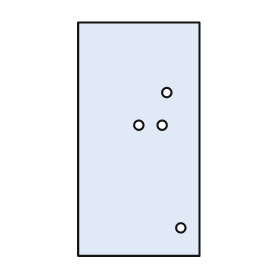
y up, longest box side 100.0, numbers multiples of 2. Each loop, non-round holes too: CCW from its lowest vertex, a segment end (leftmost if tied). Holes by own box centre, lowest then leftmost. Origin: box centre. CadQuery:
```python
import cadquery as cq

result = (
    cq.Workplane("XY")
    .moveTo(-26.0, -50.0)
    .lineTo(26.0, -50.0)
    .lineTo(26.0, 50.0)
    .lineTo(-26.0, 50.0)
    .close()
    .moveTo(18.0, -38.0)
    .circle(2.0)
    .moveTo(0.0, 6.0)
    .circle(2.0)
    .moveTo(10.0, 6.0)
    .circle(2.0)
    .moveTo(12.0, 20.0)
    .circle(2.0)
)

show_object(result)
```